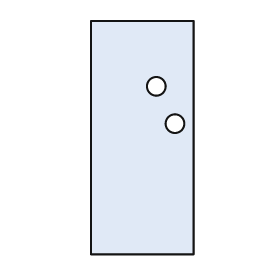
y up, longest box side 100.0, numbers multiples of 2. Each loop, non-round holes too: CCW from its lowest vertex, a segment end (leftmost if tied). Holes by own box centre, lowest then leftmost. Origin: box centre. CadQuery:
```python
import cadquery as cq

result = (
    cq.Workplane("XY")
    .moveTo(-22.0, -50.0)
    .lineTo(22.0, -50.0)
    .lineTo(22.0, 50.0)
    .lineTo(-22.0, 50.0)
    .close()
    .moveTo(14.0, 6.0)
    .circle(4.0)
    .moveTo(6.0, 22.0)
    .circle(4.0)
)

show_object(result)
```